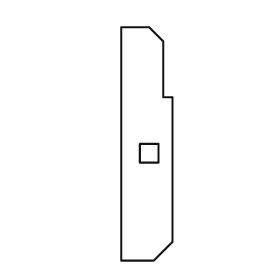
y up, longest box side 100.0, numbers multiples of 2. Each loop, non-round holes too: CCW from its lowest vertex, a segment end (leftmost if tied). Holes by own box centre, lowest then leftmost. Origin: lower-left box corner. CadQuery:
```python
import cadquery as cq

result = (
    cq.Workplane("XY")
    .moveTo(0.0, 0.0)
    .lineTo(14.0, 0.0)
    .lineTo(22.0, 8.0)
    .lineTo(22.0, 70.0)
    .lineTo(18.0, 70.0)
    .lineTo(18.0, 94.0)
    .lineTo(12.0, 100.0)
    .lineTo(0.0, 100.0)
    .close()
    .moveTo(8.0, 42.0)
    .lineTo(16.0, 42.0)
    .lineTo(16.0, 50.0)
    .lineTo(8.0, 50.0)
    .close()
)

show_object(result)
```